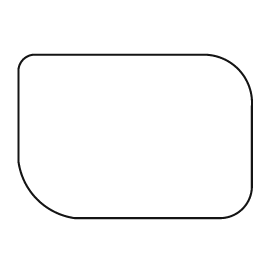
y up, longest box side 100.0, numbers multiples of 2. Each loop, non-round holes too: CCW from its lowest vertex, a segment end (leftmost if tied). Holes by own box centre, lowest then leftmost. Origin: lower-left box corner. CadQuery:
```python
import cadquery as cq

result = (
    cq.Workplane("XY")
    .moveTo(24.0, 0.0)
    .lineTo(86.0, 0.0)
    .threePointArc((96.0, 4.0), (100.0, 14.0))
    .lineTo(100.0, 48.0)
    .threePointArc((94.0, 64.0), (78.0, 70.0))
    .lineTo(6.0, 70.0)
    .threePointArc((2.0, 68.0), (0.0, 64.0))
    .lineTo(0.0, 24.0)
    .threePointArc((8.0, 8.0), (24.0, 0.0))
    .close()
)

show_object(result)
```